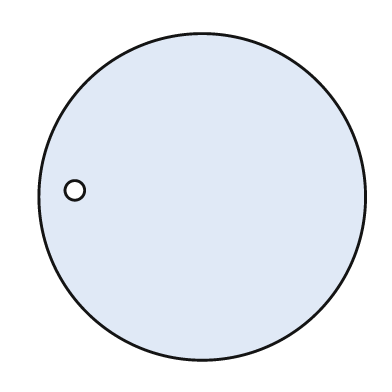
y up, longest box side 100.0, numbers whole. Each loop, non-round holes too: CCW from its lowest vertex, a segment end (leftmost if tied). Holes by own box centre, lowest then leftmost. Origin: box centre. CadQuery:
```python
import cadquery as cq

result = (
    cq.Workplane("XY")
    .moveTo(0.0, 0.0)
    .circle(50.0)
    .moveTo(-39.0, 2.0)
    .circle(3.0)
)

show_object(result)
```